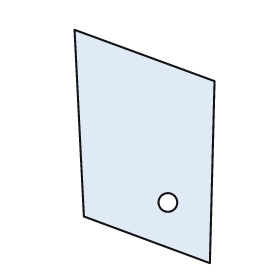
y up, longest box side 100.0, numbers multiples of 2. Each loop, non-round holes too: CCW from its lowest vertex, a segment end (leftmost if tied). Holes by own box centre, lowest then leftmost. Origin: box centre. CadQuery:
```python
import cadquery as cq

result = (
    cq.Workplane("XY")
    .moveTo(28.0, -50.0)
    .lineTo(30.0, 28.0)
    .lineTo(-30.0, 50.0)
    .lineTo(-26.0, -30.0)
    .close()
    .moveTo(10.0, -24.0)
    .circle(4.0)
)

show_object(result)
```